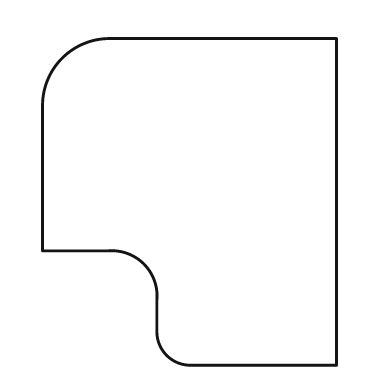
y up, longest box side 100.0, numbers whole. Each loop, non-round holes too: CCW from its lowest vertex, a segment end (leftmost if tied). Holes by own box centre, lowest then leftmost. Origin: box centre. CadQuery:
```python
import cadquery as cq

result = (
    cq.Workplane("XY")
    .moveTo(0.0, -50.0)
    .lineTo(45.0, -50.0)
    .lineTo(45.0, 50.0)
    .lineTo(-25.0, 50.0)
    .threePointArc((-39.0, 44.0), (-45.0, 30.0))
    .lineTo(-45.0, -15.0)
    .lineTo(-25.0, -15.0)
    .threePointArc((-14.0, -19.0), (-10.0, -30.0))
    .lineTo(-10.0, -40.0)
    .threePointArc((-7.0, -47.0), (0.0, -50.0))
    .close()
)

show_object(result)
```